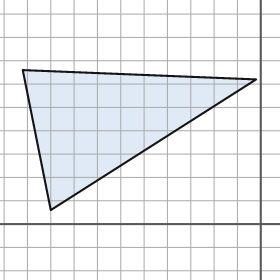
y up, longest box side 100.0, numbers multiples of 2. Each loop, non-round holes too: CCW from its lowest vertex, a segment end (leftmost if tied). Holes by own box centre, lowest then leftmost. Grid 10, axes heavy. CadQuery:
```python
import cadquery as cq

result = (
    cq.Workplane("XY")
    .moveTo(-90.0, 6.0)
    .lineTo(-2.0, 62.0)
    .lineTo(-102.0, 66.0)
    .close()
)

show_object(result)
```